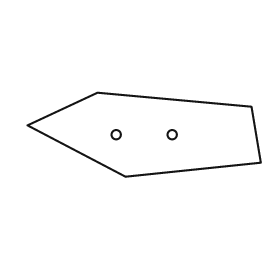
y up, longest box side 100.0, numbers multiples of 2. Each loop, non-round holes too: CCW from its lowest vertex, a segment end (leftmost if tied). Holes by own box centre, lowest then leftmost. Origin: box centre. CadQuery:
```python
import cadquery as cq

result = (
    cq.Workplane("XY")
    .moveTo(-8.0, -18.0)
    .lineTo(50.0, -12.0)
    .lineTo(46.0, 12.0)
    .lineTo(-20.0, 18.0)
    .lineTo(-50.0, 4.0)
    .close()
    .moveTo(-12.0, 0.0)
    .circle(2.0)
    .moveTo(12.0, 0.0)
    .circle(2.0)
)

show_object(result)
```